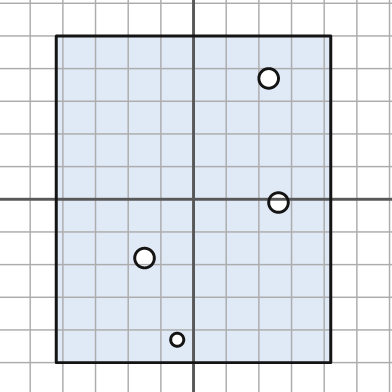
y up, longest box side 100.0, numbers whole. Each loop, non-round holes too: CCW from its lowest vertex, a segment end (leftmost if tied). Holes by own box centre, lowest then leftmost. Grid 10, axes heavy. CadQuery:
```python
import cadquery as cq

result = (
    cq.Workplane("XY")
    .moveTo(-42.0, -50.0)
    .lineTo(42.0, -50.0)
    .lineTo(42.0, 50.0)
    .lineTo(-42.0, 50.0)
    .close()
    .moveTo(-5.0, -43.0)
    .circle(2.0)
    .moveTo(-15.0, -18.0)
    .circle(3.0)
    .moveTo(26.0, -1.0)
    .circle(3.0)
    .moveTo(23.0, 37.0)
    .circle(3.0)
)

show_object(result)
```